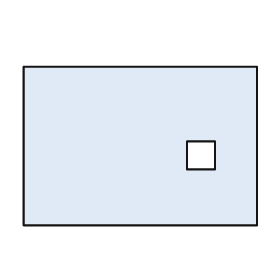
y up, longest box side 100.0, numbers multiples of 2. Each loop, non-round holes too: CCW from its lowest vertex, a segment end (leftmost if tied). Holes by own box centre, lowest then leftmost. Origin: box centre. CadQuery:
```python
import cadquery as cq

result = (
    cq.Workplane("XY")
    .moveTo(-50.0, -34.0)
    .lineTo(50.0, -34.0)
    .lineTo(50.0, 34.0)
    .lineTo(-50.0, 34.0)
    .close()
    .moveTo(20.0, -10.0)
    .lineTo(32.0, -10.0)
    .lineTo(32.0, 2.0)
    .lineTo(20.0, 2.0)
    .close()
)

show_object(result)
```